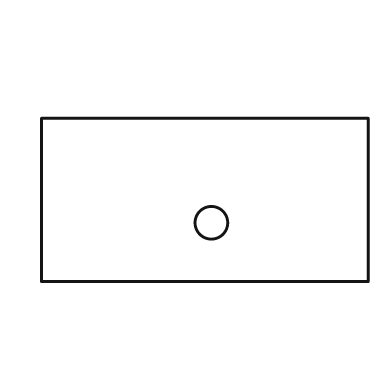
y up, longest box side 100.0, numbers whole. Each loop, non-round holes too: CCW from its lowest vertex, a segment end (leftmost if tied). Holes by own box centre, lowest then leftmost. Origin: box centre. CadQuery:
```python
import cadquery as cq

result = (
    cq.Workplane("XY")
    .moveTo(-50.0, -25.0)
    .lineTo(50.0, -25.0)
    .lineTo(50.0, 25.0)
    .lineTo(-50.0, 25.0)
    .close()
    .moveTo(2.0, -7.0)
    .circle(5.0)
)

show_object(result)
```